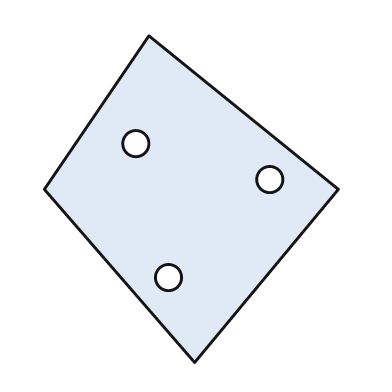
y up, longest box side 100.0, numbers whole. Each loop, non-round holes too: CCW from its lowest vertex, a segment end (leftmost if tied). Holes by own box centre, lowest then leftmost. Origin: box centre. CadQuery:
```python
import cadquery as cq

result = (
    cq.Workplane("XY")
    .moveTo(1.0, -50.0)
    .lineTo(45.0, 3.0)
    .lineTo(-13.0, 50.0)
    .lineTo(-45.0, 3.0)
    .close()
    .moveTo(-7.0, -24.0)
    .circle(4.0)
    .moveTo(24.0, 6.0)
    .circle(4.0)
    .moveTo(-17.0, 17.0)
    .circle(4.0)
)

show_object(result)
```